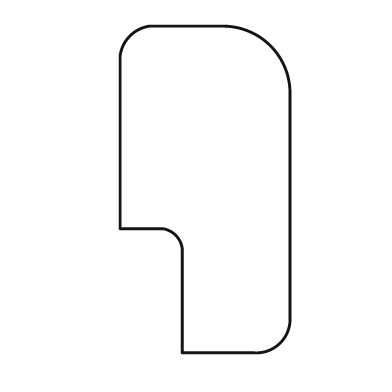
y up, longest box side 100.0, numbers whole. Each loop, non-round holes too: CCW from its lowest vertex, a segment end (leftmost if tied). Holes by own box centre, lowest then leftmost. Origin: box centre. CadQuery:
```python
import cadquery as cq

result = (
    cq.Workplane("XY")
    .moveTo(-7.0, -50.0)
    .lineTo(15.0, -50.0)
    .threePointArc((23.0, -47.0), (26.0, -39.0))
    .lineTo(26.0, 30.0)
    .threePointArc((20.0, 44.0), (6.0, 50.0))
    .lineTo(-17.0, 50.0)
    .threePointArc((-23.0, 47.0), (-26.0, 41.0))
    .lineTo(-26.0, -12.0)
    .lineTo(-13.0, -12.0)
    .threePointArc((-9.0, -14.0), (-7.0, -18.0))
    .close()
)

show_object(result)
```